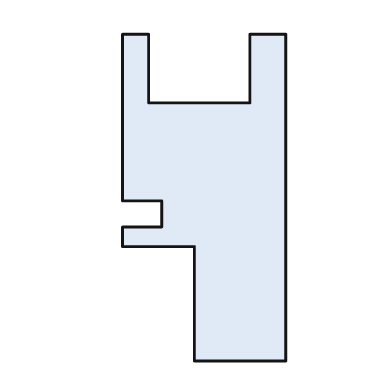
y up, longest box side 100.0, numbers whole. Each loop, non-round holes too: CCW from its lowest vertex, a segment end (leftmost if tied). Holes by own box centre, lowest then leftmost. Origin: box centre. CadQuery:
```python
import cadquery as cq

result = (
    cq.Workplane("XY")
    .moveTo(-3.0, -50.0)
    .lineTo(25.0, -50.0)
    .lineTo(25.0, 50.0)
    .lineTo(14.0, 50.0)
    .lineTo(14.0, 29.0)
    .lineTo(-17.0, 29.0)
    .lineTo(-17.0, 50.0)
    .lineTo(-25.0, 50.0)
    .lineTo(-25.0, -1.0)
    .lineTo(-13.0, -1.0)
    .lineTo(-13.0, -9.0)
    .lineTo(-25.0, -9.0)
    .lineTo(-25.0, -15.0)
    .lineTo(-3.0, -15.0)
    .close()
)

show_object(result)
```